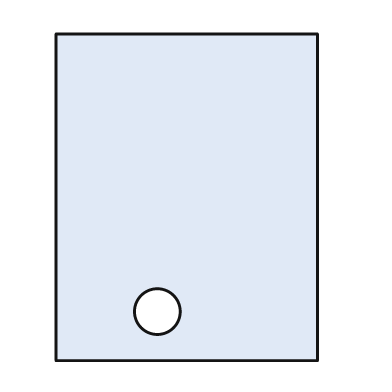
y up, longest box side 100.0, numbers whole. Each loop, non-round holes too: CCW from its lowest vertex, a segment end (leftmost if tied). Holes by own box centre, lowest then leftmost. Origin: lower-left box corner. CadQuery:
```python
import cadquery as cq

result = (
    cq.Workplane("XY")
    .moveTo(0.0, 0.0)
    .lineTo(80.0, 0.0)
    .lineTo(80.0, 100.0)
    .lineTo(0.0, 100.0)
    .close()
    .moveTo(31.0, 15.0)
    .circle(7.0)
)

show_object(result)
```